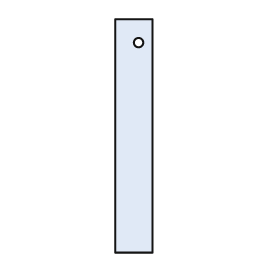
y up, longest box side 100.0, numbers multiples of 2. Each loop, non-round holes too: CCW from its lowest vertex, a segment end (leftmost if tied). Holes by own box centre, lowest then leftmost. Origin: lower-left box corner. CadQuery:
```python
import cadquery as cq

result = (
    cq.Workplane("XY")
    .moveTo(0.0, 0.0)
    .lineTo(16.0, 0.0)
    .lineTo(16.0, 100.0)
    .lineTo(0.0, 100.0)
    .close()
    .moveTo(10.0, 90.0)
    .circle(2.0)
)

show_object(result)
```